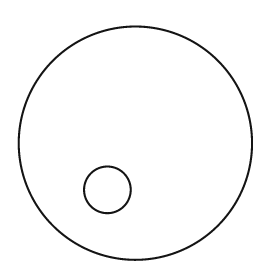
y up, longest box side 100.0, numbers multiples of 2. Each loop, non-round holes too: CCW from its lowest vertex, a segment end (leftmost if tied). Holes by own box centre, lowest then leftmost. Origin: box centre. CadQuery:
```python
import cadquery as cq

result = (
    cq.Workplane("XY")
    .moveTo(0.0, 0.0)
    .circle(50.0)
    .moveTo(-12.0, -20.0)
    .circle(10.0)
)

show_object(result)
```